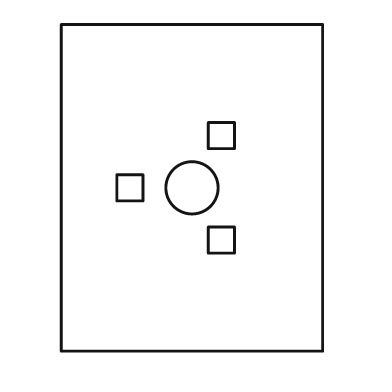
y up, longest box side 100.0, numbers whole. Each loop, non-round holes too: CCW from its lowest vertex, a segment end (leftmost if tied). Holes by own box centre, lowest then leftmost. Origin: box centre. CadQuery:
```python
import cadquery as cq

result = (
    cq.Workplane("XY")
    .moveTo(-40.0, -50.0)
    .lineTo(40.0, -50.0)
    .lineTo(40.0, 50.0)
    .lineTo(-40.0, 50.0)
    .close()
    .moveTo(5.0, -20.0)
    .lineTo(13.0, -20.0)
    .lineTo(13.0, -12.0)
    .lineTo(5.0, -12.0)
    .close()
    .moveTo(-23.0, -4.0)
    .lineTo(-15.0, -4.0)
    .lineTo(-15.0, 4.0)
    .lineTo(-23.0, 4.0)
    .close()
    .moveTo(0.0, 0.0)
    .circle(8.0)
    .moveTo(5.0, 12.0)
    .lineTo(13.0, 12.0)
    .lineTo(13.0, 20.0)
    .lineTo(5.0, 20.0)
    .close()
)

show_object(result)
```